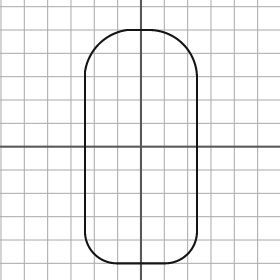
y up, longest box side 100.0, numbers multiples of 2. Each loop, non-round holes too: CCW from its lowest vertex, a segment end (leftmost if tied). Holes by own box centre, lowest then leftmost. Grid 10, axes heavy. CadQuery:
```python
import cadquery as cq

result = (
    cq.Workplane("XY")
    .moveTo(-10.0, -50.0)
    .lineTo(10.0, -50.0)
    .threePointArc((20.0, -46.0), (24.0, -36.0))
    .lineTo(24.0, 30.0)
    .threePointArc((18.0, 44.0), (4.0, 50.0))
    .lineTo(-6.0, 50.0)
    .threePointArc((-18.0, 44.0), (-24.0, 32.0))
    .lineTo(-24.0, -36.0)
    .threePointArc((-20.0, -46.0), (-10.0, -50.0))
    .close()
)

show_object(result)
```